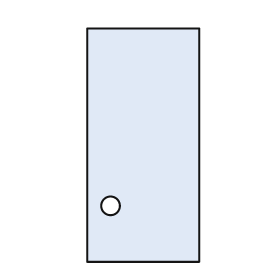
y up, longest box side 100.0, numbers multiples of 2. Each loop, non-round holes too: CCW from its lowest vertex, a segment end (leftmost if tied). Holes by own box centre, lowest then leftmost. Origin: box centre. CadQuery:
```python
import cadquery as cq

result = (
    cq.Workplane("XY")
    .moveTo(-24.0, -50.0)
    .lineTo(24.0, -50.0)
    .lineTo(24.0, 50.0)
    .lineTo(-24.0, 50.0)
    .close()
    .moveTo(-14.0, -26.0)
    .circle(4.0)
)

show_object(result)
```